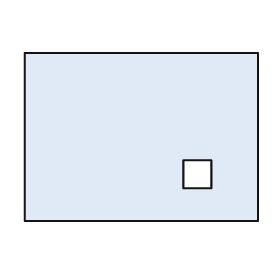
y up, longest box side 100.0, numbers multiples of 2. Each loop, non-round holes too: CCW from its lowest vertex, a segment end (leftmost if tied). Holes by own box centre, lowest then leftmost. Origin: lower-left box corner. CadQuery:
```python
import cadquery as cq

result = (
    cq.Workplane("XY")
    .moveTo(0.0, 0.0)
    .lineTo(100.0, 0.0)
    .lineTo(100.0, 72.0)
    .lineTo(0.0, 72.0)
    .close()
    .moveTo(68.0, 14.0)
    .lineTo(80.0, 14.0)
    .lineTo(80.0, 26.0)
    .lineTo(68.0, 26.0)
    .close()
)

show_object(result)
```